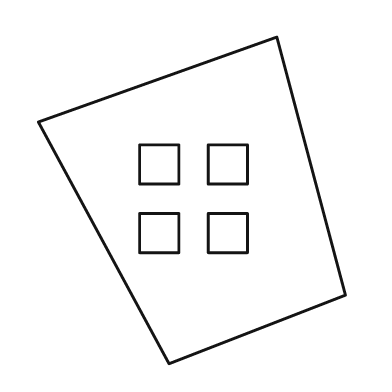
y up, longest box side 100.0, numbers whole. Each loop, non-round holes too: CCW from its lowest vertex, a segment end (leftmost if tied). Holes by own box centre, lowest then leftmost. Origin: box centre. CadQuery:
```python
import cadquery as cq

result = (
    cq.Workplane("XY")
    .moveTo(-7.0, -50.0)
    .lineTo(47.0, -29.0)
    .lineTo(26.0, 50.0)
    .lineTo(-47.0, 24.0)
    .close()
    .moveTo(-16.0, -16.0)
    .lineTo(-4.0, -16.0)
    .lineTo(-4.0, -4.0)
    .lineTo(-16.0, -4.0)
    .close()
    .moveTo(5.0, -16.0)
    .lineTo(17.0, -16.0)
    .lineTo(17.0, -4.0)
    .lineTo(5.0, -4.0)
    .close()
    .moveTo(-16.0, 5.0)
    .lineTo(-4.0, 5.0)
    .lineTo(-4.0, 17.0)
    .lineTo(-16.0, 17.0)
    .close()
    .moveTo(5.0, 5.0)
    .lineTo(17.0, 5.0)
    .lineTo(17.0, 17.0)
    .lineTo(5.0, 17.0)
    .close()
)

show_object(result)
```